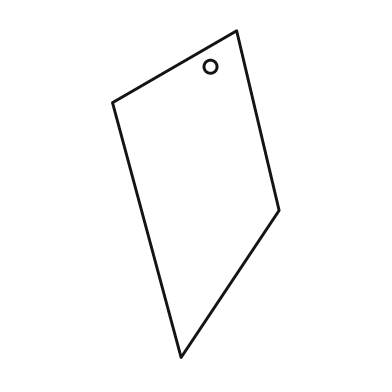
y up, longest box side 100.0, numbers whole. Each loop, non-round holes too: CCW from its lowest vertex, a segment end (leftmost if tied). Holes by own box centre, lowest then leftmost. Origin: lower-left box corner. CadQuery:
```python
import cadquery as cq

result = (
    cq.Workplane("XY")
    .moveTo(21.0, 0.0)
    .lineTo(51.0, 45.0)
    .lineTo(38.0, 100.0)
    .lineTo(0.0, 78.0)
    .close()
    .moveTo(30.0, 89.0)
    .circle(2.0)
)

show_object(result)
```